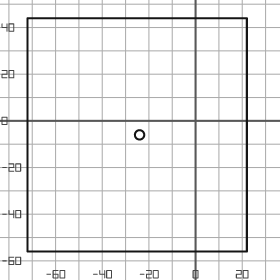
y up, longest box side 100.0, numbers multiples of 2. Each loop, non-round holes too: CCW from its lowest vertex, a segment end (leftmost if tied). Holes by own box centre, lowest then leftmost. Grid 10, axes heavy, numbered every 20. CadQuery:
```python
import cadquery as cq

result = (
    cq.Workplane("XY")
    .moveTo(-72.0, -56.0)
    .lineTo(22.0, -56.0)
    .lineTo(22.0, 44.0)
    .lineTo(-72.0, 44.0)
    .close()
    .moveTo(-24.0, -6.0)
    .circle(2.0)
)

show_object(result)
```